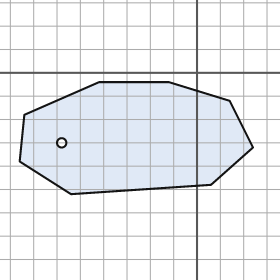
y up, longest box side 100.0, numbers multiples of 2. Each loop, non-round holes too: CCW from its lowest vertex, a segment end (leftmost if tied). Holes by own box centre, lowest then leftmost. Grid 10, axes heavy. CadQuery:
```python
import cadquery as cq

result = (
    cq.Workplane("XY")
    .moveTo(-54.0, -52.0)
    .lineTo(6.0, -48.0)
    .lineTo(24.0, -32.0)
    .lineTo(14.0, -12.0)
    .lineTo(-12.0, -4.0)
    .lineTo(-42.0, -4.0)
    .lineTo(-74.0, -18.0)
    .lineTo(-76.0, -38.0)
    .close()
    .moveTo(-58.0, -30.0)
    .circle(2.0)
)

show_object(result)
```